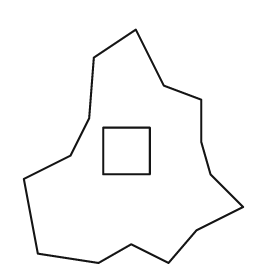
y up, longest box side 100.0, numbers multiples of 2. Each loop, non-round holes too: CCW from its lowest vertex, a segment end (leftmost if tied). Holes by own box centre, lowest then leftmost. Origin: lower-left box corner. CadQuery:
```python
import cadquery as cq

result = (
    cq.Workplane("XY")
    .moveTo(32.0, 0.0)
    .lineTo(46.0, 8.0)
    .lineTo(62.0, 0.0)
    .lineTo(74.0, 14.0)
    .lineTo(94.0, 24.0)
    .lineTo(80.0, 38.0)
    .lineTo(76.0, 52.0)
    .lineTo(76.0, 70.0)
    .lineTo(60.0, 76.0)
    .lineTo(48.0, 100.0)
    .lineTo(30.0, 88.0)
    .lineTo(28.0, 62.0)
    .lineTo(20.0, 46.0)
    .lineTo(0.0, 36.0)
    .lineTo(6.0, 4.0)
    .close()
    .moveTo(34.0, 38.0)
    .lineTo(54.0, 38.0)
    .lineTo(54.0, 58.0)
    .lineTo(34.0, 58.0)
    .close()
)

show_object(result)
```